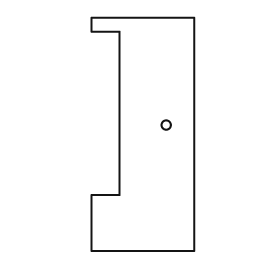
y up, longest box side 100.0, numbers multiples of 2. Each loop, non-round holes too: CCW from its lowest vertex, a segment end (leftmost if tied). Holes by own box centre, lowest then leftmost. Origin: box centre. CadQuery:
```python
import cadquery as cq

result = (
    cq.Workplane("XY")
    .moveTo(-22.0, -50.0)
    .lineTo(22.0, -50.0)
    .lineTo(22.0, 50.0)
    .lineTo(-22.0, 50.0)
    .lineTo(-22.0, 44.0)
    .lineTo(-10.0, 44.0)
    .lineTo(-10.0, -26.0)
    .lineTo(-22.0, -26.0)
    .close()
    .moveTo(10.0, 4.0)
    .circle(2.0)
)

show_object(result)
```